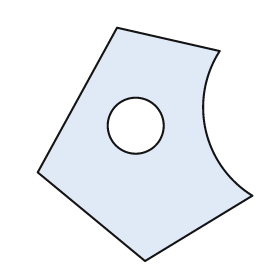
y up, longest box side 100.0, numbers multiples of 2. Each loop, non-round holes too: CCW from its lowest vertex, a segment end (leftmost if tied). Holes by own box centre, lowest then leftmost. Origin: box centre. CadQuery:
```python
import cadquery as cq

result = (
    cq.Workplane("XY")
    .moveTo(0.0, -50.0)
    .lineTo(46.0, -22.0)
    .threePointArc((26.0, 6.0), (32.0, 40.0))
    .lineTo(-12.0, 50.0)
    .lineTo(-46.0, -12.0)
    .close()
    .moveTo(-4.0, 8.0)
    .circle(12.0)
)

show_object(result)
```